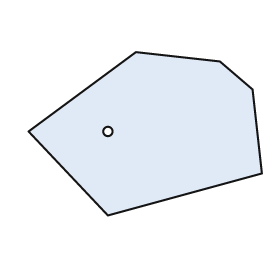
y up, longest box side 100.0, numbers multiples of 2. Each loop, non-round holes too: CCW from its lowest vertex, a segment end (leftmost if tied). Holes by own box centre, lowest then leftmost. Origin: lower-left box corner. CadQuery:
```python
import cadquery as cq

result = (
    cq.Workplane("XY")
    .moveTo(34.0, 0.0)
    .lineTo(100.0, 18.0)
    .lineTo(96.0, 54.0)
    .lineTo(82.0, 66.0)
    .lineTo(46.0, 70.0)
    .lineTo(0.0, 36.0)
    .close()
    .moveTo(34.0, 36.0)
    .circle(2.0)
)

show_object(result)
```